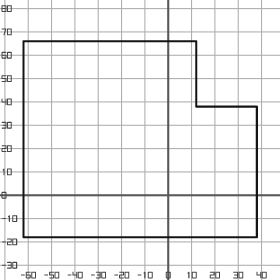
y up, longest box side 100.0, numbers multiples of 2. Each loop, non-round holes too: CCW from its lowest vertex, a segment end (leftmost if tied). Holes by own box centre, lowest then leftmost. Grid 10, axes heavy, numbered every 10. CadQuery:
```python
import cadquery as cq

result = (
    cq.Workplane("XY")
    .moveTo(-62.0, -18.0)
    .lineTo(38.0, -18.0)
    .lineTo(38.0, 38.0)
    .lineTo(12.0, 38.0)
    .lineTo(12.0, 66.0)
    .lineTo(-62.0, 66.0)
    .close()
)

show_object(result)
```